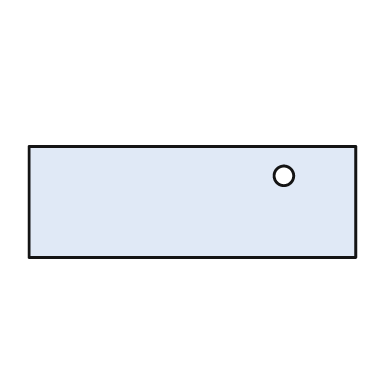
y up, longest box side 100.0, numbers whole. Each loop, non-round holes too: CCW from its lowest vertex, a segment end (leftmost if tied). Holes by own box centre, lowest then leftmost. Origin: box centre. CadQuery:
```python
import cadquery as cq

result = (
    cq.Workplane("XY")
    .moveTo(-50.0, -17.0)
    .lineTo(50.0, -17.0)
    .lineTo(50.0, 17.0)
    .lineTo(-50.0, 17.0)
    .close()
    .moveTo(28.0, 8.0)
    .circle(3.0)
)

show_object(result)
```